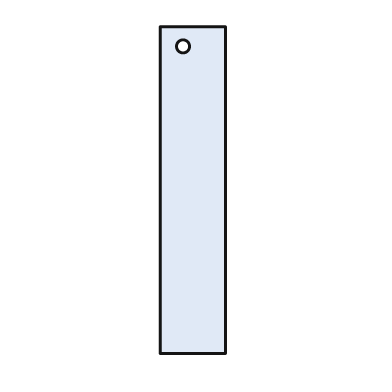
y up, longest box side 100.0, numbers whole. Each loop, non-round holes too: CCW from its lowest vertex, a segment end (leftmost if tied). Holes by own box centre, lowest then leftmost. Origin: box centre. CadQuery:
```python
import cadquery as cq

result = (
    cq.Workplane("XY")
    .moveTo(-10.0, -50.0)
    .lineTo(10.0, -50.0)
    .lineTo(10.0, 50.0)
    .lineTo(-10.0, 50.0)
    .close()
    .moveTo(-3.0, 44.0)
    .circle(2.0)
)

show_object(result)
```